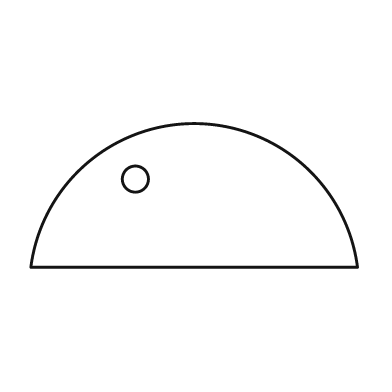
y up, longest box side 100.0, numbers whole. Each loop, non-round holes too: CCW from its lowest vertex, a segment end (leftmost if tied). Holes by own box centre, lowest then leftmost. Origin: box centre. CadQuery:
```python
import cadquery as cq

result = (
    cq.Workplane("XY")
    .moveTo(-50.0, -22.0)
    .lineTo(50.0, -22.0)
    .threePointArc((0.0, 22.0), (-50.0, -22.0))
    .close()
    .moveTo(-18.0, 5.0)
    .circle(4.0)
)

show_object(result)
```